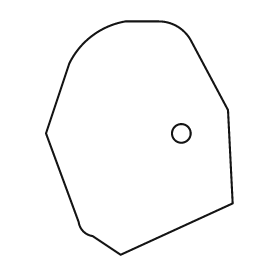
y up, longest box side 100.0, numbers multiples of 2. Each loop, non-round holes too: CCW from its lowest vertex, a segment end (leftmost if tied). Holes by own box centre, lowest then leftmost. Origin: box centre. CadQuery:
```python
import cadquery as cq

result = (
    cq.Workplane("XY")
    .moveTo(-8.0, -50.0)
    .lineTo(40.0, -28.0)
    .lineTo(38.0, 12.0)
    .lineTo(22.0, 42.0)
    .threePointArc((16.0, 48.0), (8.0, 50.0))
    .lineTo(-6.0, 50.0)
    .threePointArc((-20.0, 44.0), (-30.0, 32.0))
    .lineTo(-40.0, 2.0)
    .lineTo(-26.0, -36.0)
    .threePointArc((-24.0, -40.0), (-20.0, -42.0))
    .close()
    .moveTo(18.0, 2.0)
    .circle(4.0)
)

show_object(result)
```